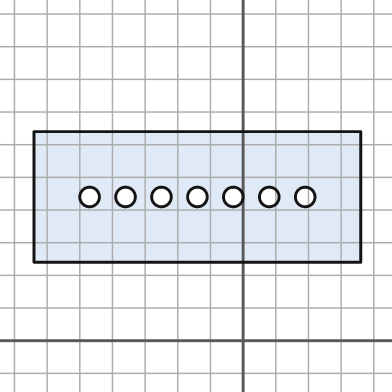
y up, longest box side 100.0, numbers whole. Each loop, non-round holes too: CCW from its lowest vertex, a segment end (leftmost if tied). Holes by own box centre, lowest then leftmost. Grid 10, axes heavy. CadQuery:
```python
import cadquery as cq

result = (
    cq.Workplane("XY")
    .moveTo(-64.0, 24.0)
    .lineTo(36.0, 24.0)
    .lineTo(36.0, 64.0)
    .lineTo(-64.0, 64.0)
    .close()
    .moveTo(-47.0, 44.0)
    .circle(3.0)
    .moveTo(-36.0, 44.0)
    .circle(3.0)
    .moveTo(-25.0, 44.0)
    .circle(3.0)
    .moveTo(-14.0, 44.0)
    .circle(3.0)
    .moveTo(-3.0, 44.0)
    .circle(3.0)
    .moveTo(8.0, 44.0)
    .circle(3.0)
    .moveTo(19.0, 44.0)
    .circle(3.0)
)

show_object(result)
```